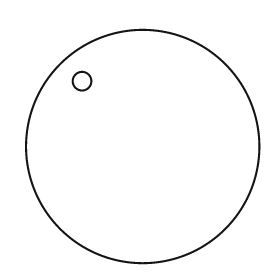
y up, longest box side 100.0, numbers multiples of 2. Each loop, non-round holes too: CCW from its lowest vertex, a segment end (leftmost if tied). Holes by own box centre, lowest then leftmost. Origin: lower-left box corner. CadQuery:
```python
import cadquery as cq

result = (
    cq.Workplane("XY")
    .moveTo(50.0, 50.0)
    .circle(50.0)
    .moveTo(24.0, 78.0)
    .circle(4.0)
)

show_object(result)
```